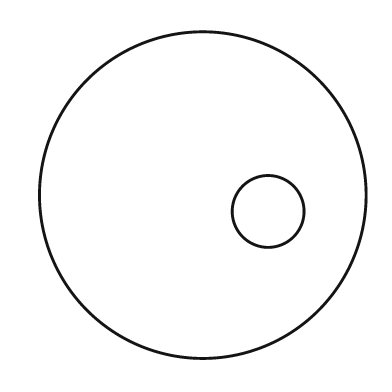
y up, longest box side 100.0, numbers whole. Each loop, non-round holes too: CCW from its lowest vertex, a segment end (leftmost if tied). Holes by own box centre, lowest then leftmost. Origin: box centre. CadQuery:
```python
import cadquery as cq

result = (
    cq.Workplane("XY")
    .moveTo(0.0, 0.0)
    .circle(50.0)
    .moveTo(20.0, -5.0)
    .circle(11.0)
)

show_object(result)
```